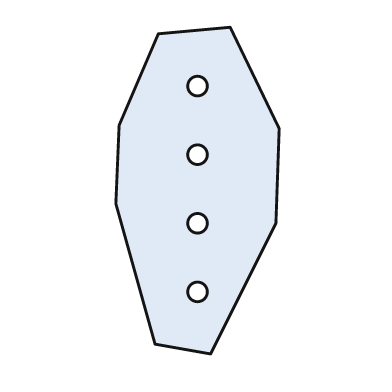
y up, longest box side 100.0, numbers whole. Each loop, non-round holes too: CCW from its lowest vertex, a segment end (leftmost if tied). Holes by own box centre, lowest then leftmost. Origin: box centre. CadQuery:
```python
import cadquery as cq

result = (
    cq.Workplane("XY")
    .moveTo(4.0, -50.0)
    .lineTo(24.0, -10.0)
    .lineTo(25.0, 19.0)
    .lineTo(10.0, 50.0)
    .lineTo(-12.0, 48.0)
    .lineTo(-24.0, 20.0)
    .lineTo(-25.0, -4.0)
    .lineTo(-13.0, -47.0)
    .close()
    .moveTo(0.0, -31.0)
    .circle(3.0)
    .moveTo(0.0, -10.0)
    .circle(3.0)
    .moveTo(0.0, 11.0)
    .circle(3.0)
    .moveTo(0.0, 32.0)
    .circle(3.0)
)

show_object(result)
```